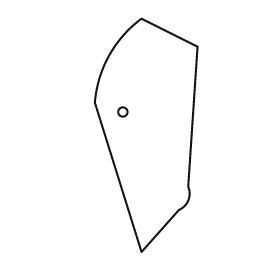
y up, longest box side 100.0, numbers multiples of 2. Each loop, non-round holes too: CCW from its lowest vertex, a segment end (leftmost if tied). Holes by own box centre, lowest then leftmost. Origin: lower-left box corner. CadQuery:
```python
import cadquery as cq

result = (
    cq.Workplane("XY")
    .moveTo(20.0, 0.0)
    .lineTo(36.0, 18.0)
    .threePointArc((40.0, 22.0), (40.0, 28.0))
    .lineTo(44.0, 88.0)
    .lineTo(20.0, 100.0)
    .threePointArc((6.0, 84.0), (0.0, 64.0))
    .close()
    .moveTo(12.0, 60.0)
    .circle(2.0)
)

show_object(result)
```